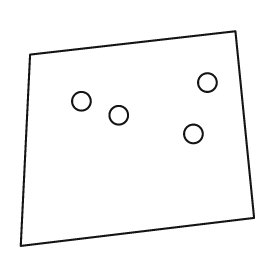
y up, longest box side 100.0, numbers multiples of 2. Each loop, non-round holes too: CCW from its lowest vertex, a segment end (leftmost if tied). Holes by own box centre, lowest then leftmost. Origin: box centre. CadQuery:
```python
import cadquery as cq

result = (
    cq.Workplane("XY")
    .moveTo(-50.0, -46.0)
    .lineTo(50.0, -34.0)
    .lineTo(42.0, 46.0)
    .lineTo(-46.0, 36.0)
    .close()
    .moveTo(24.0, 2.0)
    .circle(4.0)
    .moveTo(-8.0, 10.0)
    .circle(4.0)
    .moveTo(-24.0, 16.0)
    .circle(4.0)
    .moveTo(30.0, 24.0)
    .circle(4.0)
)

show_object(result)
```